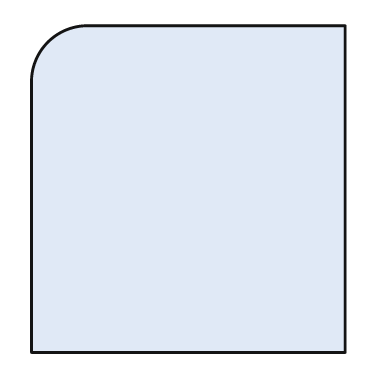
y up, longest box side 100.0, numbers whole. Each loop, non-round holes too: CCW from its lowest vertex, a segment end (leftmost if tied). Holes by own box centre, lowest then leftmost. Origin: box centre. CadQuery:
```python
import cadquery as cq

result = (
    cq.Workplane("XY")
    .moveTo(-48.0, -50.0)
    .lineTo(48.0, -50.0)
    .lineTo(48.0, 50.0)
    .lineTo(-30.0, 50.0)
    .threePointArc((-43.0, 45.0), (-48.0, 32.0))
    .close()
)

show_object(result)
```